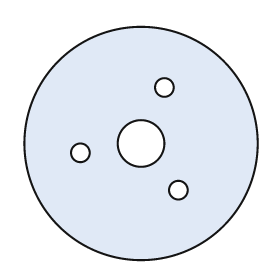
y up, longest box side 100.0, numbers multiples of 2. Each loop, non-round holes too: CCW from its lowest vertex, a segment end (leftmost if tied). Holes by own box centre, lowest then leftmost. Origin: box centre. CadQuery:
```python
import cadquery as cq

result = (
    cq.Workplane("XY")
    .moveTo(0.0, 0.0)
    .circle(50.0)
    .moveTo(16.0, -20.0)
    .circle(4.0)
    .moveTo(-26.0, -4.0)
    .circle(4.0)
    .moveTo(0.0, 0.0)
    .circle(10.0)
    .moveTo(10.0, 24.0)
    .circle(4.0)
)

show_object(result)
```